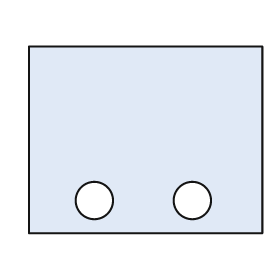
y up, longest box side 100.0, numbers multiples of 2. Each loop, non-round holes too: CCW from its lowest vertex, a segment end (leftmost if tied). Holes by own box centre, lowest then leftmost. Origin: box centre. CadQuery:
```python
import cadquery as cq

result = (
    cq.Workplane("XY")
    .moveTo(-50.0, -40.0)
    .lineTo(50.0, -40.0)
    .lineTo(50.0, 40.0)
    .lineTo(-50.0, 40.0)
    .close()
    .moveTo(-22.0, -26.0)
    .circle(8.0)
    .moveTo(20.0, -26.0)
    .circle(8.0)
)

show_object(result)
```